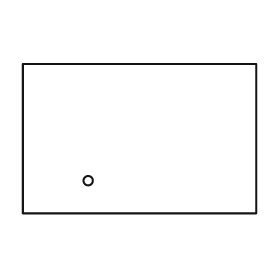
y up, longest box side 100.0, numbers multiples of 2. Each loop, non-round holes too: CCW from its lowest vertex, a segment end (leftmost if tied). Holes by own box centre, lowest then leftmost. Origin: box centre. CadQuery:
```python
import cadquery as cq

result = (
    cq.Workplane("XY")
    .moveTo(-50.0, -32.0)
    .lineTo(50.0, -32.0)
    .lineTo(50.0, 32.0)
    .lineTo(-50.0, 32.0)
    .close()
    .moveTo(-22.0, -18.0)
    .circle(2.0)
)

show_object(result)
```